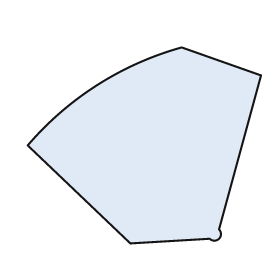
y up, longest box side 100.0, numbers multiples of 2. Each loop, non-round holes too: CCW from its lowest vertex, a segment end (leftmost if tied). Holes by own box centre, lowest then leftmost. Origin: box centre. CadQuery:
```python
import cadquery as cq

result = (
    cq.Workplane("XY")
    .moveTo(-6.0, -42.0)
    .lineTo(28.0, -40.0)
    .threePointArc((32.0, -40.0), (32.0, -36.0))
    .lineTo(50.0, 30.0)
    .lineTo(16.0, 42.0)
    .threePointArc((-20.0, 26.0), (-50.0, 0.0))
    .close()
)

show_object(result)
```